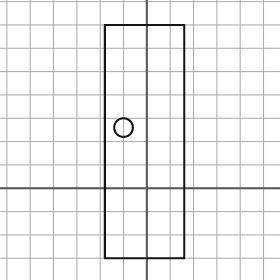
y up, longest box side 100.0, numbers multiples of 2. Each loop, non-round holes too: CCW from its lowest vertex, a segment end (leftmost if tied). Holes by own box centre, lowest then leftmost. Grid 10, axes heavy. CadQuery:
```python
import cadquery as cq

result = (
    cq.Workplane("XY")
    .moveTo(-18.0, -30.0)
    .lineTo(16.0, -30.0)
    .lineTo(16.0, 70.0)
    .lineTo(-18.0, 70.0)
    .close()
    .moveTo(-10.0, 26.0)
    .circle(4.0)
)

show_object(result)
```